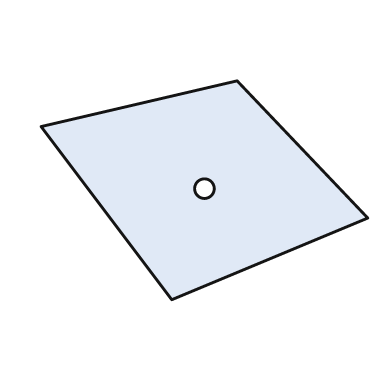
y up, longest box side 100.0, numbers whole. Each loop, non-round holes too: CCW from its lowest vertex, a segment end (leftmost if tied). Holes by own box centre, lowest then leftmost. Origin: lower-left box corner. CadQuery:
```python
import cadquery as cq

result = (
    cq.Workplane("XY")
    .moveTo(40.0, 0.0)
    .lineTo(100.0, 25.0)
    .lineTo(60.0, 67.0)
    .lineTo(0.0, 53.0)
    .close()
    .moveTo(50.0, 34.0)
    .circle(3.0)
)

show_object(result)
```